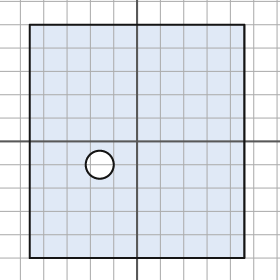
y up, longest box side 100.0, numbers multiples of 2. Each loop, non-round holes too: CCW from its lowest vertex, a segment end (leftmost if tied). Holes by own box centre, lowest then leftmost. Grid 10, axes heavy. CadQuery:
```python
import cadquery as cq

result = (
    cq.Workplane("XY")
    .moveTo(-46.0, -50.0)
    .lineTo(46.0, -50.0)
    .lineTo(46.0, 50.0)
    .lineTo(-46.0, 50.0)
    .close()
    .moveTo(-16.0, -10.0)
    .circle(6.0)
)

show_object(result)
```